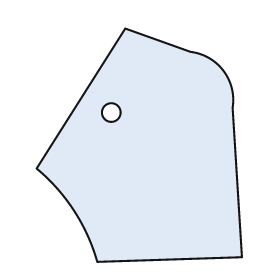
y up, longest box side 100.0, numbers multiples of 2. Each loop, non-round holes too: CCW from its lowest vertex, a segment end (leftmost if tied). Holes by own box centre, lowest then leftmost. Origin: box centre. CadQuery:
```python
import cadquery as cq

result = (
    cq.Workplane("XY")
    .moveTo(-18.0, -50.0)
    .lineTo(44.0, -48.0)
    .lineTo(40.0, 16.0)
    .threePointArc((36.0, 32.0), (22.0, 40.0))
    .lineTo(-6.0, 50.0)
    .lineTo(-44.0, -10.0)
    .threePointArc((-28.0, -28.0), (-18.0, -50.0))
    .close()
    .moveTo(-12.0, 14.0)
    .circle(4.0)
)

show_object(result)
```